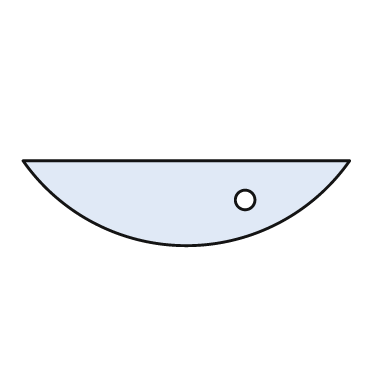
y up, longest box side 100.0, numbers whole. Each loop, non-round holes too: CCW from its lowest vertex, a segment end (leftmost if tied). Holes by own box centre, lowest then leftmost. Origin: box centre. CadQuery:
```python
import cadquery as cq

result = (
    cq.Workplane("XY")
    .moveTo(-50.0, 13.0)
    .threePointArc((0.0, -13.0), (50.0, 13.0))
    .close()
    .moveTo(18.0, 1.0)
    .circle(3.0)
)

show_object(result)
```